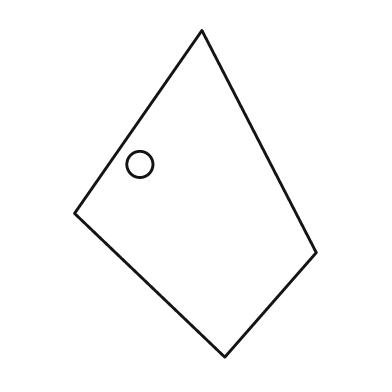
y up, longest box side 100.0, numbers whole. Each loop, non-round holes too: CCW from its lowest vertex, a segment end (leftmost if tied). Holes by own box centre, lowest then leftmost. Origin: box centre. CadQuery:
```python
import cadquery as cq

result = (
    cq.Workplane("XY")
    .moveTo(9.0, -50.0)
    .lineTo(37.0, -18.0)
    .lineTo(2.0, 50.0)
    .lineTo(-37.0, -6.0)
    .close()
    .moveTo(-17.0, 9.0)
    .circle(4.0)
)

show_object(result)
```